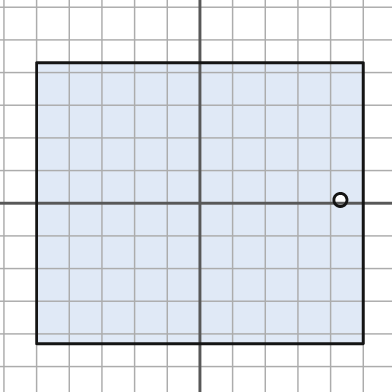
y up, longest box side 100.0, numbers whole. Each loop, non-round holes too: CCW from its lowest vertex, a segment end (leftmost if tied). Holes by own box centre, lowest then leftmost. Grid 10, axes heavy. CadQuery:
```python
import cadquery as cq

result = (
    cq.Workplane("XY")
    .moveTo(-50.0, -43.0)
    .lineTo(50.0, -43.0)
    .lineTo(50.0, 43.0)
    .lineTo(-50.0, 43.0)
    .close()
    .moveTo(43.0, 1.0)
    .circle(2.0)
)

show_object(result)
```